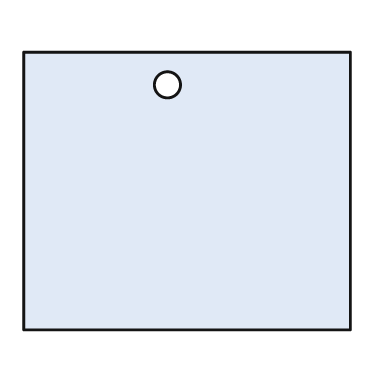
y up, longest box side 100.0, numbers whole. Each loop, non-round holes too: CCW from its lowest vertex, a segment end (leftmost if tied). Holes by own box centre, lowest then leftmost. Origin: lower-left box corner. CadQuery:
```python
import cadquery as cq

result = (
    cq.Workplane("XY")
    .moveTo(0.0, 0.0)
    .lineTo(100.0, 0.0)
    .lineTo(100.0, 85.0)
    .lineTo(0.0, 85.0)
    .close()
    .moveTo(44.0, 75.0)
    .circle(4.0)
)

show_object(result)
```